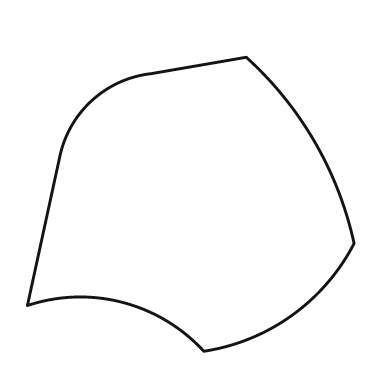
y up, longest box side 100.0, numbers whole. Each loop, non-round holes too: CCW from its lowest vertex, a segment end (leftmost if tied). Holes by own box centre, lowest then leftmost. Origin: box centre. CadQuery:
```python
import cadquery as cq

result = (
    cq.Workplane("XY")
    .moveTo(4.0, -45.0)
    .threePointArc((31.0, -34.0), (50.0, -12.0))
    .threePointArc((38.0, 19.0), (17.0, 45.0))
    .lineTo(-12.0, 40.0)
    .threePointArc((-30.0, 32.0), (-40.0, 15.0))
    .lineTo(-50.0, -31.0)
    .threePointArc((-21.0, -30.0), (4.0, -45.0))
    .close()
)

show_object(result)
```